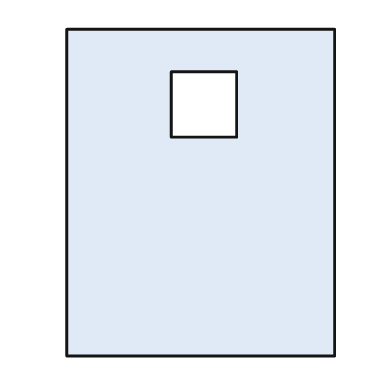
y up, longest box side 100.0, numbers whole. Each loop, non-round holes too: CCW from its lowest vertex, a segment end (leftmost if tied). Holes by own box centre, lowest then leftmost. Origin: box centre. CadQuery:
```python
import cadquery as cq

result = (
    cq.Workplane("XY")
    .moveTo(-41.0, -50.0)
    .lineTo(41.0, -50.0)
    .lineTo(41.0, 50.0)
    .lineTo(-41.0, 50.0)
    .close()
    .moveTo(-9.0, 17.0)
    .lineTo(11.0, 17.0)
    .lineTo(11.0, 37.0)
    .lineTo(-9.0, 37.0)
    .close()
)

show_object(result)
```